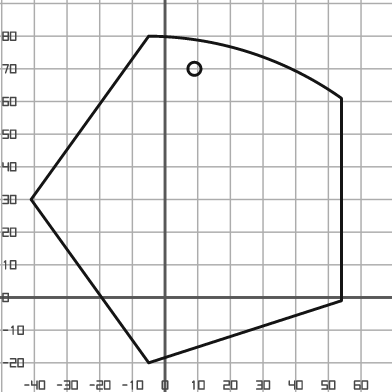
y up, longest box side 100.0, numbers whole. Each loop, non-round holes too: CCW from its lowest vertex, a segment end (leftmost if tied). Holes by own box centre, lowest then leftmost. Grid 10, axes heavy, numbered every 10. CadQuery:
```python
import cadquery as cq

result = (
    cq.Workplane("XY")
    .moveTo(-5.0, -20.0)
    .lineTo(54.0, -1.0)
    .lineTo(54.0, 61.0)
    .threePointArc((26.0, 75.0), (-5.0, 80.0))
    .lineTo(-41.0, 30.0)
    .close()
    .moveTo(9.0, 70.0)
    .circle(2.0)
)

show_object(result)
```